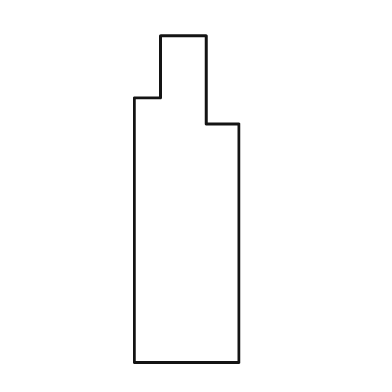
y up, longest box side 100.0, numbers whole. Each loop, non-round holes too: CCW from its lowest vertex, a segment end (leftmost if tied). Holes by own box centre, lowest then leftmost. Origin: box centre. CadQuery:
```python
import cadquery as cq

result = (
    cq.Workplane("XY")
    .moveTo(-16.0, -50.0)
    .lineTo(16.0, -50.0)
    .lineTo(16.0, 23.0)
    .lineTo(6.0, 23.0)
    .lineTo(6.0, 50.0)
    .lineTo(-8.0, 50.0)
    .lineTo(-8.0, 31.0)
    .lineTo(-16.0, 31.0)
    .close()
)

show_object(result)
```